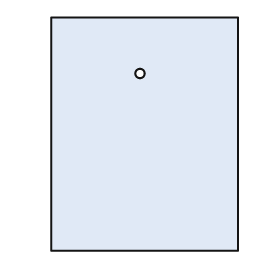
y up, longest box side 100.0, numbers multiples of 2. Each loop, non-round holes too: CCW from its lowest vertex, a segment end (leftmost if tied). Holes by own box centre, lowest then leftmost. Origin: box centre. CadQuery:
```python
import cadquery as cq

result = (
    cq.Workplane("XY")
    .moveTo(-40.0, -50.0)
    .lineTo(40.0, -50.0)
    .lineTo(40.0, 50.0)
    .lineTo(-40.0, 50.0)
    .close()
    .moveTo(-2.0, 26.0)
    .circle(2.0)
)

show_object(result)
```